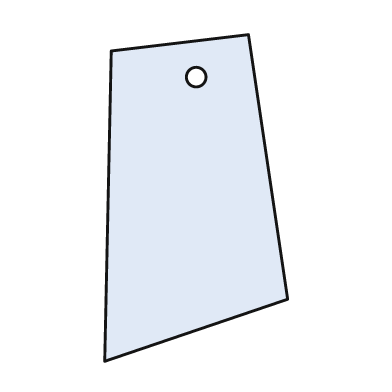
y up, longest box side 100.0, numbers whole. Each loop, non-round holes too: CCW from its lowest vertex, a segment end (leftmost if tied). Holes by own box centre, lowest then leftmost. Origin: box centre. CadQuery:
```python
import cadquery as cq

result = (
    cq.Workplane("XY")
    .moveTo(-28.0, -50.0)
    .lineTo(28.0, -31.0)
    .lineTo(16.0, 50.0)
    .lineTo(-26.0, 45.0)
    .close()
    .moveTo(0.0, 37.0)
    .circle(3.0)
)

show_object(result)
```